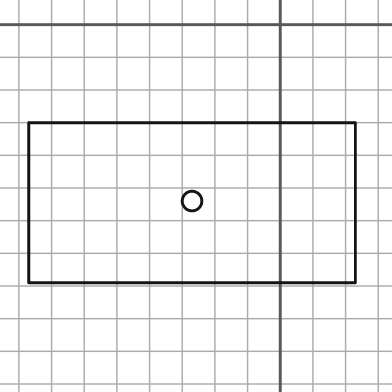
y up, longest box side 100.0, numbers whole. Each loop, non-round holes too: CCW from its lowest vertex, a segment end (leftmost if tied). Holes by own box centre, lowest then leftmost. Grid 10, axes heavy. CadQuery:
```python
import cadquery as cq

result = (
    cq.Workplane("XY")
    .moveTo(-77.0, -79.0)
    .lineTo(23.0, -79.0)
    .lineTo(23.0, -30.0)
    .lineTo(-77.0, -30.0)
    .close()
    .moveTo(-27.0, -54.0)
    .circle(3.0)
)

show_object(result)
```